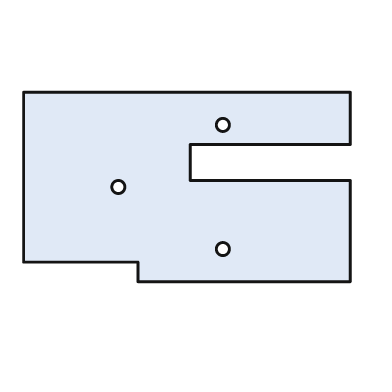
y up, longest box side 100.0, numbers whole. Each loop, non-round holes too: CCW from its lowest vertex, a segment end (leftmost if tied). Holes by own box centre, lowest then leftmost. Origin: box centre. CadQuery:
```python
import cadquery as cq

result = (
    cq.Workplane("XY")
    .moveTo(-15.0, -29.0)
    .lineTo(50.0, -29.0)
    .lineTo(50.0, 2.0)
    .lineTo(1.0, 2.0)
    .lineTo(1.0, 13.0)
    .lineTo(50.0, 13.0)
    .lineTo(50.0, 29.0)
    .lineTo(-50.0, 29.0)
    .lineTo(-50.0, -23.0)
    .lineTo(-15.0, -23.0)
    .close()
    .moveTo(11.0, -19.0)
    .circle(2.0)
    .moveTo(-21.0, 0.0)
    .circle(2.0)
    .moveTo(11.0, 19.0)
    .circle(2.0)
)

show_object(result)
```